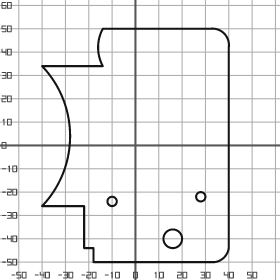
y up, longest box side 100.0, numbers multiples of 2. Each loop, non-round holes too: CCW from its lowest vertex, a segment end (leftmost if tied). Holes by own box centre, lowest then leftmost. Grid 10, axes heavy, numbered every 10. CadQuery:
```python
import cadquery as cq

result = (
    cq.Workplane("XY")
    .moveTo(-18.0, -50.0)
    .lineTo(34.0, -50.0)
    .threePointArc((38.0, -48.0), (40.0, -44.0))
    .lineTo(40.0, 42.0)
    .threePointArc((38.0, 48.0), (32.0, 50.0))
    .lineTo(-14.0, 50.0)
    .threePointArc((-16.0, 42.0), (-14.0, 34.0))
    .lineTo(-40.0, 34.0)
    .threePointArc((-28.0, 4.0), (-40.0, -26.0))
    .lineTo(-22.0, -26.0)
    .lineTo(-22.0, -44.0)
    .lineTo(-18.0, -44.0)
    .close()
    .moveTo(16.0, -40.0)
    .circle(4.0)
    .moveTo(-10.0, -24.0)
    .circle(2.0)
    .moveTo(28.0, -22.0)
    .circle(2.0)
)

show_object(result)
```